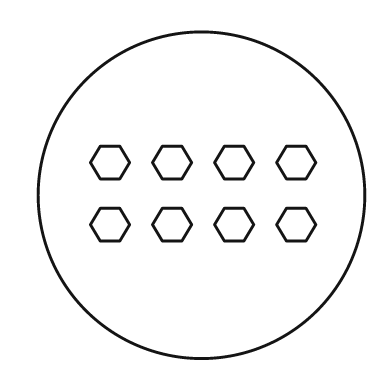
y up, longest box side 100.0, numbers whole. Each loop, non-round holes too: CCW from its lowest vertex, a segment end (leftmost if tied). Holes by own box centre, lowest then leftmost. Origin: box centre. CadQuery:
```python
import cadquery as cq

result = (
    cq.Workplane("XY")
    .moveTo(0.0, 0.0)
    .circle(50.0)
    .moveTo(-31.0, -14.0)
    .lineTo(-25.0, -14.0)
    .lineTo(-22.0, -9.0)
    .lineTo(-25.0, -4.0)
    .lineTo(-31.0, -4.0)
    .lineTo(-34.0, -9.0)
    .close()
    .moveTo(-12.0, -14.0)
    .lineTo(-6.0, -14.0)
    .lineTo(-3.0, -9.0)
    .lineTo(-6.0, -4.0)
    .lineTo(-12.0, -4.0)
    .lineTo(-15.0, -9.0)
    .close()
    .moveTo(7.0, -14.0)
    .lineTo(13.0, -14.0)
    .lineTo(16.0, -9.0)
    .lineTo(13.0, -4.0)
    .lineTo(7.0, -4.0)
    .lineTo(4.0, -9.0)
    .close()
    .moveTo(26.0, -14.0)
    .lineTo(32.0, -14.0)
    .lineTo(35.0, -9.0)
    .lineTo(32.0, -4.0)
    .lineTo(26.0, -4.0)
    .lineTo(23.0, -9.0)
    .close()
    .moveTo(-31.0, 5.0)
    .lineTo(-25.0, 5.0)
    .lineTo(-22.0, 10.0)
    .lineTo(-25.0, 15.0)
    .lineTo(-31.0, 15.0)
    .lineTo(-34.0, 10.0)
    .close()
    .moveTo(-12.0, 5.0)
    .lineTo(-6.0, 5.0)
    .lineTo(-3.0, 10.0)
    .lineTo(-6.0, 15.0)
    .lineTo(-12.0, 15.0)
    .lineTo(-15.0, 10.0)
    .close()
    .moveTo(7.0, 5.0)
    .lineTo(13.0, 5.0)
    .lineTo(16.0, 10.0)
    .lineTo(13.0, 15.0)
    .lineTo(7.0, 15.0)
    .lineTo(4.0, 10.0)
    .close()
    .moveTo(26.0, 5.0)
    .lineTo(32.0, 5.0)
    .lineTo(35.0, 10.0)
    .lineTo(32.0, 15.0)
    .lineTo(26.0, 15.0)
    .lineTo(23.0, 10.0)
    .close()
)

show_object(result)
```